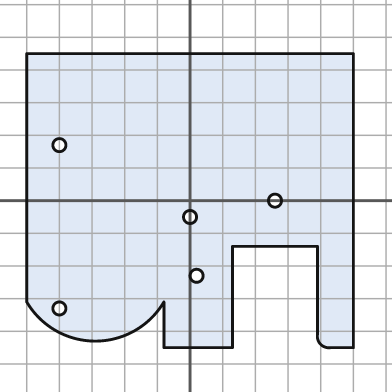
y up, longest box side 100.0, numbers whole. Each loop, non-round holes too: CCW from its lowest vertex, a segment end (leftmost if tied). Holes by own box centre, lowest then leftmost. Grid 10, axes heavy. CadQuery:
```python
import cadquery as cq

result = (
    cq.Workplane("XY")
    .moveTo(-8.0, -45.0)
    .lineTo(13.0, -45.0)
    .lineTo(13.0, -14.0)
    .lineTo(39.0, -14.0)
    .lineTo(39.0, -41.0)
    .threePointArc((40.0, -44.0), (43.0, -45.0))
    .lineTo(50.0, -45.0)
    .lineTo(50.0, 45.0)
    .lineTo(-50.0, 45.0)
    .lineTo(-50.0, -31.0)
    .threePointArc((-29.0, -43.0), (-8.0, -31.0))
    .close()
    .moveTo(-40.0, -33.0)
    .circle(2.0)
    .moveTo(2.0, -23.0)
    .circle(2.0)
    .moveTo(0.0, -5.0)
    .circle(2.0)
    .moveTo(26.0, 0.0)
    .circle(2.0)
    .moveTo(-40.0, 17.0)
    .circle(2.0)
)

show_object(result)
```